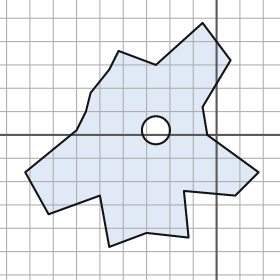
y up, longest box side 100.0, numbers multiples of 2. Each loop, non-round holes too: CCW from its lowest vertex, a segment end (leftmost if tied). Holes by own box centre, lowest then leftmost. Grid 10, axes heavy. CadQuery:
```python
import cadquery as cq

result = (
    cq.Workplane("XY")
    .moveTo(-46.0, -48.0)
    .lineTo(-30.0, -42.0)
    .lineTo(-12.0, -44.0)
    .lineTo(-14.0, -24.0)
    .lineTo(8.0, -26.0)
    .lineTo(18.0, -16.0)
    .lineTo(-4.0, 0.0)
    .lineTo(-6.0, 12.0)
    .lineTo(6.0, 32.0)
    .lineTo(-6.0, 48.0)
    .lineTo(-26.0, 30.0)
    .lineTo(-42.0, 36.0)
    .lineTo(-46.0, 28.0)
    .lineTo(-54.0, 18.0)
    .lineTo(-56.0, 10.0)
    .lineTo(-60.0, 2.0)
    .lineTo(-82.0, -16.0)
    .lineTo(-72.0, -34.0)
    .lineTo(-50.0, -26.0)
    .close()
    .moveTo(-26.0, 2.0)
    .circle(6.0)
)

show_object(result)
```